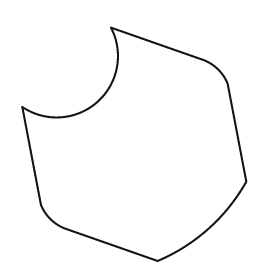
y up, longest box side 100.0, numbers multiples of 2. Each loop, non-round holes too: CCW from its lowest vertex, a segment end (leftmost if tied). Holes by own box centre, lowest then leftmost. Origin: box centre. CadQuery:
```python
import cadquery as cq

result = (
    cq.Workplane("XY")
    .moveTo(10.0, -50.0)
    .threePointArc((32.0, -36.0), (48.0, -16.0))
    .lineTo(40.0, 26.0)
    .threePointArc((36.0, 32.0), (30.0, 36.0))
    .lineTo(-10.0, 50.0)
    .threePointArc((-16.0, 18.0), (-48.0, 16.0))
    .lineTo(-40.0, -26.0)
    .threePointArc((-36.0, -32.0), (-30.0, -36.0))
    .close()
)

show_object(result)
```